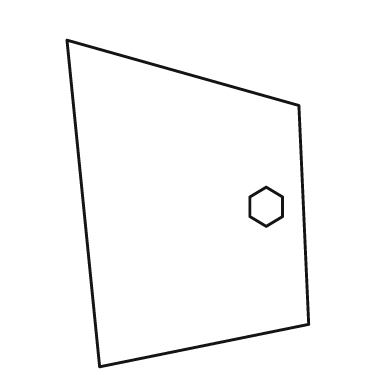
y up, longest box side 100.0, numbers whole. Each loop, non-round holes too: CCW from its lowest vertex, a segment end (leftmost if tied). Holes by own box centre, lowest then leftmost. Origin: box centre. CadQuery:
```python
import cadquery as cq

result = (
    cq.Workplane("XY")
    .moveTo(-27.0, -50.0)
    .lineTo(37.0, -37.0)
    .lineTo(34.0, 30.0)
    .lineTo(-37.0, 50.0)
    .close()
    .moveTo(24.0, -7.0)
    .lineTo(29.0, -4.0)
    .lineTo(29.0, 2.0)
    .lineTo(24.0, 5.0)
    .lineTo(19.0, 2.0)
    .lineTo(19.0, -4.0)
    .close()
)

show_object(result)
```